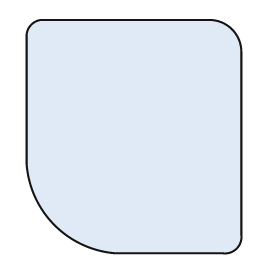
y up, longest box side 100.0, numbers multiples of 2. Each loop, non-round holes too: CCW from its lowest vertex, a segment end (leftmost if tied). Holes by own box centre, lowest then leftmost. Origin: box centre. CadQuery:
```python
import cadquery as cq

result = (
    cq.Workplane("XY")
    .moveTo(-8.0, -50.0)
    .lineTo(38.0, -50.0)
    .threePointArc((44.0, -48.0), (46.0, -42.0))
    .lineTo(46.0, 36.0)
    .threePointArc((42.0, 46.0), (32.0, 50.0))
    .lineTo(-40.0, 50.0)
    .threePointArc((-44.0, 48.0), (-46.0, 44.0))
    .lineTo(-46.0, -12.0)
    .threePointArc((-34.0, -38.0), (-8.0, -50.0))
    .close()
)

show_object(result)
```